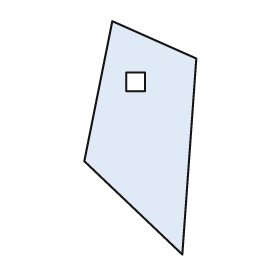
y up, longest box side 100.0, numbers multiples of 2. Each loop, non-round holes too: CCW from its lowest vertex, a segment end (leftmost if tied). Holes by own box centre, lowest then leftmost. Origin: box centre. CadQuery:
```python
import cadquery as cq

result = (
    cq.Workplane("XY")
    .moveTo(18.0, -50.0)
    .lineTo(24.0, 34.0)
    .lineTo(-12.0, 50.0)
    .lineTo(-24.0, -10.0)
    .close()
    .moveTo(-6.0, 20.0)
    .lineTo(2.0, 20.0)
    .lineTo(2.0, 28.0)
    .lineTo(-6.0, 28.0)
    .close()
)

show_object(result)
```